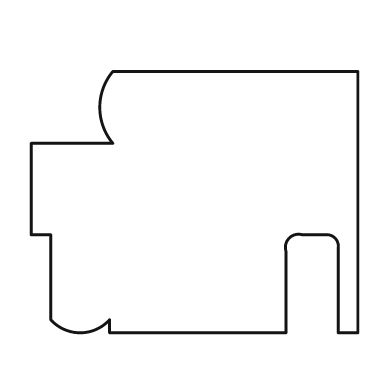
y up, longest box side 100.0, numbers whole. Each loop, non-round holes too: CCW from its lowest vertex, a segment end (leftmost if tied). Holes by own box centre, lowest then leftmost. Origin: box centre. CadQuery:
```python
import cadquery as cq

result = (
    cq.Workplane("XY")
    .moveTo(-26.0, -40.0)
    .lineTo(28.0, -40.0)
    .lineTo(28.0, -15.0)
    .threePointArc((29.0, -11.0), (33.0, -10.0))
    .lineTo(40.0, -10.0)
    .threePointArc((43.0, -11.0), (44.0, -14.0))
    .lineTo(44.0, -40.0)
    .lineTo(50.0, -40.0)
    .lineTo(50.0, 40.0)
    .lineTo(-25.0, 40.0)
    .threePointArc((-29.0, 29.0), (-25.0, 18.0))
    .lineTo(-50.0, 18.0)
    .lineTo(-50.0, -10.0)
    .lineTo(-44.0, -10.0)
    .lineTo(-44.0, -36.0)
    .threePointArc((-35.0, -40.0), (-26.0, -36.0))
    .close()
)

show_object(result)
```